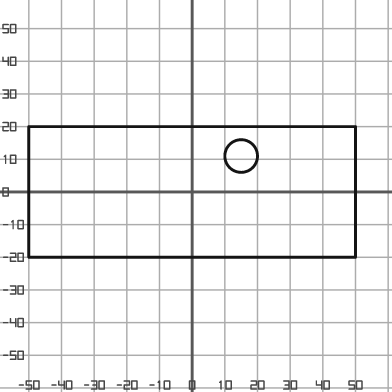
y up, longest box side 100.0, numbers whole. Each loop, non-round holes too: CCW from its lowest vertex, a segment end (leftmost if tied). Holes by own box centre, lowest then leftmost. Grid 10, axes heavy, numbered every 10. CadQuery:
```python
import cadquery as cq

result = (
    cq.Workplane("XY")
    .moveTo(-50.0, -20.0)
    .lineTo(50.0, -20.0)
    .lineTo(50.0, 20.0)
    .lineTo(-50.0, 20.0)
    .close()
    .moveTo(15.0, 11.0)
    .circle(5.0)
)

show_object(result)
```